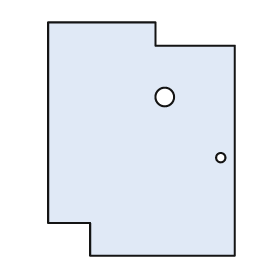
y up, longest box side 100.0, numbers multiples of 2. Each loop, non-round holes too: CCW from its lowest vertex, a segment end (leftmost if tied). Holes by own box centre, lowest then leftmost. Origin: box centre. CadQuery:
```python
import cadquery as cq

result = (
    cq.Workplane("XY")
    .moveTo(-22.0, -50.0)
    .lineTo(40.0, -50.0)
    .lineTo(40.0, 40.0)
    .lineTo(6.0, 40.0)
    .lineTo(6.0, 50.0)
    .lineTo(-40.0, 50.0)
    .lineTo(-40.0, -36.0)
    .lineTo(-22.0, -36.0)
    .close()
    .moveTo(34.0, -8.0)
    .circle(2.0)
    .moveTo(10.0, 18.0)
    .circle(4.0)
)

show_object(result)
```